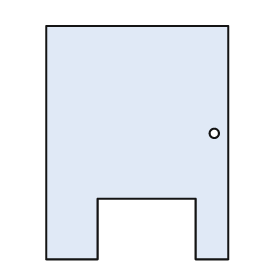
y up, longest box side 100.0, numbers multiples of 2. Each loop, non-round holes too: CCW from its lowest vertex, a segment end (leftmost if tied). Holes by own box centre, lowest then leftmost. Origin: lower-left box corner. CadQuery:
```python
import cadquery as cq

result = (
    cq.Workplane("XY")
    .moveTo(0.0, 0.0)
    .lineTo(22.0, 0.0)
    .lineTo(22.0, 26.0)
    .lineTo(64.0, 26.0)
    .lineTo(64.0, 0.0)
    .lineTo(78.0, 0.0)
    .lineTo(78.0, 100.0)
    .lineTo(0.0, 100.0)
    .close()
    .moveTo(72.0, 54.0)
    .circle(2.0)
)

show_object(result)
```